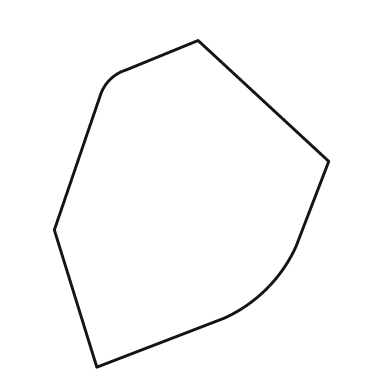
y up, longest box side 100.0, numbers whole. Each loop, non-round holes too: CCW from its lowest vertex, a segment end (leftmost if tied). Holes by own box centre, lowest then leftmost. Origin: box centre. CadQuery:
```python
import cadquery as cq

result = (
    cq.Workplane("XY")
    .moveTo(-29.0, -50.0)
    .lineTo(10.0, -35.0)
    .threePointArc((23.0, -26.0), (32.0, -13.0))
    .lineTo(42.0, 13.0)
    .lineTo(2.0, 50.0)
    .lineTo(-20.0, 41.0)
    .threePointArc((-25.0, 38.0), (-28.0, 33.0))
    .lineTo(-42.0, -8.0)
    .close()
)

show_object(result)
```